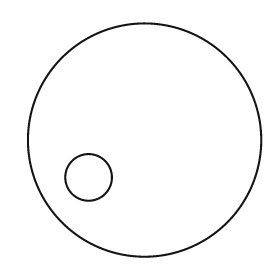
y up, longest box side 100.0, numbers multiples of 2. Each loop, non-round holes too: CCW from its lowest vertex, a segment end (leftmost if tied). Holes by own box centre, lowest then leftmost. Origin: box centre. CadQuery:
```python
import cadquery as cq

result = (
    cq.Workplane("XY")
    .moveTo(0.0, 0.0)
    .circle(50.0)
    .moveTo(-24.0, -16.0)
    .circle(10.0)
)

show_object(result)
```